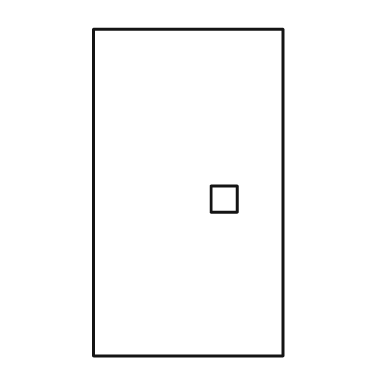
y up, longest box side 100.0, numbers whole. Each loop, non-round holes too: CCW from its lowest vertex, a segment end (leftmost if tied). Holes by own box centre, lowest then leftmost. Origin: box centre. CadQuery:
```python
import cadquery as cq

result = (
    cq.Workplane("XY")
    .moveTo(-29.0, -50.0)
    .lineTo(29.0, -50.0)
    .lineTo(29.0, 50.0)
    .lineTo(-29.0, 50.0)
    .close()
    .moveTo(7.0, -6.0)
    .lineTo(15.0, -6.0)
    .lineTo(15.0, 2.0)
    .lineTo(7.0, 2.0)
    .close()
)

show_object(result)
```